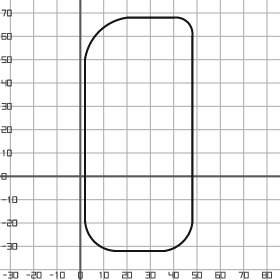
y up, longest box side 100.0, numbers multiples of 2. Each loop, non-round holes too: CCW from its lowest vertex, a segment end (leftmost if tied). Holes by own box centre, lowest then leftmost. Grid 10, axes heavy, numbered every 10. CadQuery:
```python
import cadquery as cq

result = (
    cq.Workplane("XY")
    .moveTo(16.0, -32.0)
    .lineTo(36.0, -32.0)
    .threePointArc((44.0, -28.0), (48.0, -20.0))
    .lineTo(48.0, 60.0)
    .threePointArc((46.0, 66.0), (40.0, 68.0))
    .lineTo(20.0, 68.0)
    .threePointArc((8.0, 62.0), (2.0, 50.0))
    .lineTo(2.0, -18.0)
    .threePointArc((6.0, -28.0), (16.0, -32.0))
    .close()
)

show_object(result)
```